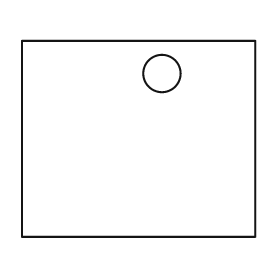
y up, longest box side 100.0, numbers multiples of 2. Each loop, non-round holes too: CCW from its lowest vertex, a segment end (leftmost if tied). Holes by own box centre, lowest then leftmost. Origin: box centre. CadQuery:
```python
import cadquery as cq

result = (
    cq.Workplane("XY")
    .moveTo(-50.0, -42.0)
    .lineTo(50.0, -42.0)
    .lineTo(50.0, 42.0)
    .lineTo(-50.0, 42.0)
    .close()
    .moveTo(10.0, 28.0)
    .circle(8.0)
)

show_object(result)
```